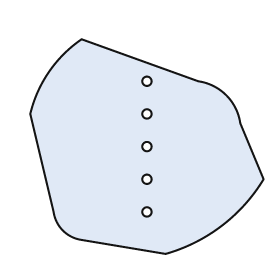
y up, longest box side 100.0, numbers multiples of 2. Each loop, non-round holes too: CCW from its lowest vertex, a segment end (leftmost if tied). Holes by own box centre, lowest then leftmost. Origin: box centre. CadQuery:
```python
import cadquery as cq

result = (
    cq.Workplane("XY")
    .moveTo(8.0, -46.0)
    .threePointArc((32.0, -34.0), (50.0, -14.0))
    .lineTo(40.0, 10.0)
    .threePointArc((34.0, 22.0), (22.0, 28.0))
    .lineTo(-28.0, 46.0)
    .threePointArc((-42.0, 32.0), (-50.0, 14.0))
    .lineTo(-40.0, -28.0)
    .threePointArc((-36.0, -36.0), (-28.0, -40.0))
    .close()
    .moveTo(0.0, -28.0)
    .circle(2.0)
    .moveTo(0.0, -14.0)
    .circle(2.0)
    .moveTo(0.0, 0.0)
    .circle(2.0)
    .moveTo(0.0, 14.0)
    .circle(2.0)
    .moveTo(0.0, 28.0)
    .circle(2.0)
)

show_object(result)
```